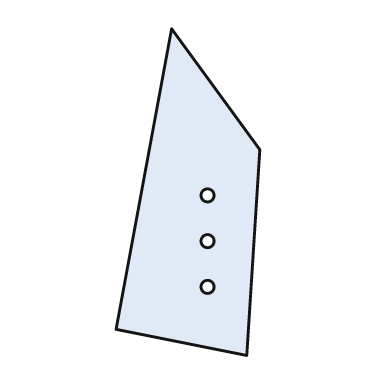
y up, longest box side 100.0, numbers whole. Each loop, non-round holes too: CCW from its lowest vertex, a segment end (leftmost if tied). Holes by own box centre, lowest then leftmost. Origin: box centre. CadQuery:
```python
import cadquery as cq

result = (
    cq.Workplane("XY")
    .moveTo(18.0, -50.0)
    .lineTo(22.0, 13.0)
    .lineTo(-5.0, 50.0)
    .lineTo(-22.0, -42.0)
    .close()
    .moveTo(6.0, -29.0)
    .circle(2.0)
    .moveTo(6.0, -15.0)
    .circle(2.0)
    .moveTo(6.0, -1.0)
    .circle(2.0)
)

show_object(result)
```